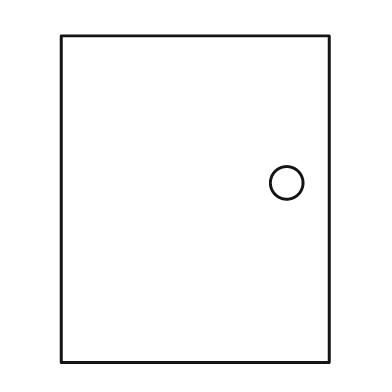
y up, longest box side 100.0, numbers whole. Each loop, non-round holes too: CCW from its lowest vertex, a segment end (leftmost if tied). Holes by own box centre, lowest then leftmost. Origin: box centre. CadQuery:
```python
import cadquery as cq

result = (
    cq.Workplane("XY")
    .moveTo(-41.0, -50.0)
    .lineTo(41.0, -50.0)
    .lineTo(41.0, 50.0)
    .lineTo(-41.0, 50.0)
    .close()
    .moveTo(28.0, 5.0)
    .circle(5.0)
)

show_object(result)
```